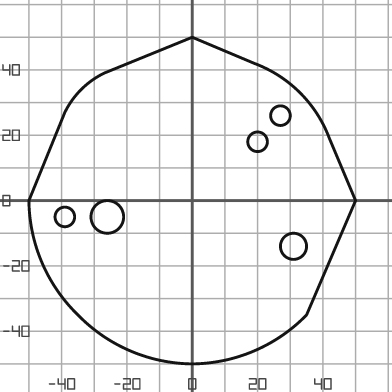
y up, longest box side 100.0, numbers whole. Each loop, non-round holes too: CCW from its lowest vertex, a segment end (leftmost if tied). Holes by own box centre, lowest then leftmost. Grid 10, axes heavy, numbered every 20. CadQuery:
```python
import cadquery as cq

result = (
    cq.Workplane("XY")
    .moveTo(0.0, -50.0)
    .threePointArc((19.0, -46.0), (35.0, -35.0))
    .lineTo(50.0, 0.0)
    .lineTo(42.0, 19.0)
    .threePointArc((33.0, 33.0), (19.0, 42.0))
    .lineTo(0.0, 50.0)
    .lineTo(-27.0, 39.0)
    .threePointArc((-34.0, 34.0), (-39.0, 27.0))
    .lineTo(-50.0, 0.0)
    .threePointArc((-46.0, -19.0), (-35.0, -35.0))
    .threePointArc((-19.0, -46.0), (0.0, -50.0))
    .close()
    .moveTo(31.0, -14.0)
    .circle(4.0)
    .moveTo(-39.0, -5.0)
    .circle(3.0)
    .moveTo(-26.0, -5.0)
    .circle(5.0)
    .moveTo(20.0, 18.0)
    .circle(3.0)
    .moveTo(27.0, 26.0)
    .circle(3.0)
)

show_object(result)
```